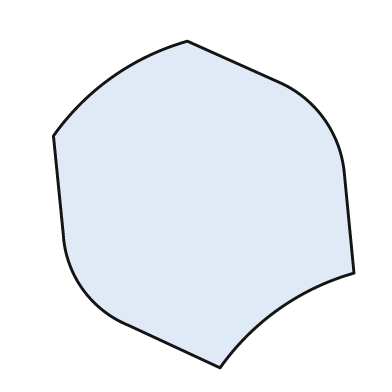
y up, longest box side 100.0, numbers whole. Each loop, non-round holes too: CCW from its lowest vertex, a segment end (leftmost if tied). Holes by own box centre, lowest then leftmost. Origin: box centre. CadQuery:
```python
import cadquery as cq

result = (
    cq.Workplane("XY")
    .moveTo(5.0, -50.0)
    .threePointArc((23.0, -32.0), (46.0, -21.0))
    .lineTo(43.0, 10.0)
    .threePointArc((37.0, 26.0), (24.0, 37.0))
    .lineTo(-5.0, 50.0)
    .threePointArc((-28.0, 39.0), (-46.0, 21.0))
    .lineTo(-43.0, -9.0)
    .threePointArc((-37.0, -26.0), (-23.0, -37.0))
    .close()
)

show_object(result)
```